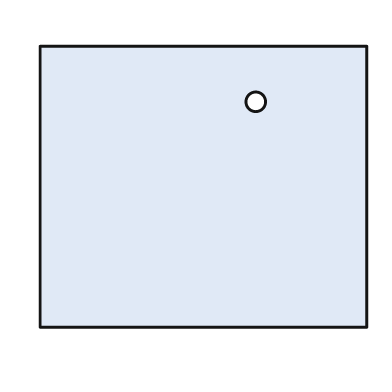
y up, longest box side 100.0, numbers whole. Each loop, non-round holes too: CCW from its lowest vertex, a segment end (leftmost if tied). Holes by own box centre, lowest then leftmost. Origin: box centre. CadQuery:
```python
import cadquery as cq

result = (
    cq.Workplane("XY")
    .moveTo(-50.0, -43.0)
    .lineTo(50.0, -43.0)
    .lineTo(50.0, 43.0)
    .lineTo(-50.0, 43.0)
    .close()
    .moveTo(16.0, 26.0)
    .circle(3.0)
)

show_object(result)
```